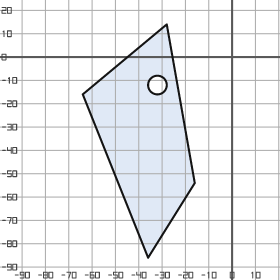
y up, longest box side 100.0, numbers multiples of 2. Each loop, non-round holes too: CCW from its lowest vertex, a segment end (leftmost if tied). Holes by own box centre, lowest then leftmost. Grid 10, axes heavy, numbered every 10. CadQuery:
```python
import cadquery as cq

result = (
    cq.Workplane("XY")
    .moveTo(-36.0, -86.0)
    .lineTo(-16.0, -54.0)
    .lineTo(-28.0, 14.0)
    .lineTo(-64.0, -16.0)
    .close()
    .moveTo(-32.0, -12.0)
    .circle(4.0)
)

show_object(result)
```